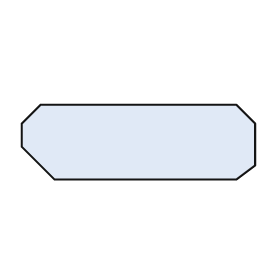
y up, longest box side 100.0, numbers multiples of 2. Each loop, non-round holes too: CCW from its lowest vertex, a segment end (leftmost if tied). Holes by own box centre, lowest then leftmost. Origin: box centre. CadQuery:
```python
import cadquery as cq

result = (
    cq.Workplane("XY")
    .moveTo(-36.0, -16.0)
    .lineTo(42.0, -16.0)
    .lineTo(50.0, -10.0)
    .lineTo(50.0, 8.0)
    .lineTo(42.0, 16.0)
    .lineTo(-42.0, 16.0)
    .lineTo(-50.0, 8.0)
    .lineTo(-50.0, -2.0)
    .close()
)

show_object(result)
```